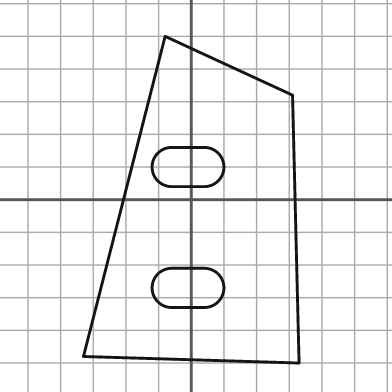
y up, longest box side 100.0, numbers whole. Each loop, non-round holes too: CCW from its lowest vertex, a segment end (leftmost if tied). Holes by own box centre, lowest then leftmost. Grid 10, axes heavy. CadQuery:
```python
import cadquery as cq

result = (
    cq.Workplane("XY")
    .moveTo(33.0, -50.0)
    .lineTo(31.0, 32.0)
    .lineTo(-8.0, 50.0)
    .lineTo(-33.0, -48.0)
    .close()
    .moveTo(-6.0, -33.0)
    .lineTo(4.0, -33.0)
    .threePointArc((10.0, -27.0), (4.0, -21.0))
    .lineTo(-6.0, -21.0)
    .threePointArc((-12.0, -27.0), (-6.0, -33.0))
    .close()
    .moveTo(-6.0, 4.0)
    .lineTo(4.0, 4.0)
    .threePointArc((10.0, 10.0), (4.0, 16.0))
    .lineTo(-6.0, 16.0)
    .threePointArc((-12.0, 10.0), (-6.0, 4.0))
    .close()
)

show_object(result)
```